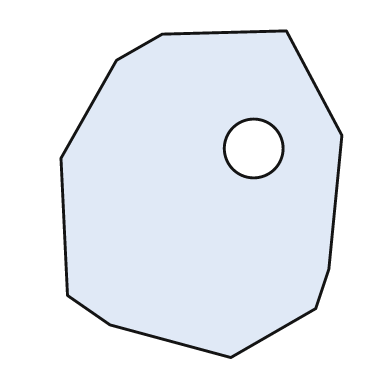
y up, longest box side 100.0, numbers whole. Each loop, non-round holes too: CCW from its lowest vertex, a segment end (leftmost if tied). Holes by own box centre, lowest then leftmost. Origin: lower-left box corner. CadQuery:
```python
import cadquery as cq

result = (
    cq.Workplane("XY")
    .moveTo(52.0, 0.0)
    .lineTo(78.0, 15.0)
    .lineTo(82.0, 27.0)
    .lineTo(86.0, 68.0)
    .lineTo(69.0, 100.0)
    .lineTo(31.0, 99.0)
    .lineTo(17.0, 91.0)
    .lineTo(0.0, 61.0)
    .lineTo(2.0, 19.0)
    .lineTo(15.0, 10.0)
    .close()
    .moveTo(59.0, 64.0)
    .circle(9.0)
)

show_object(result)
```